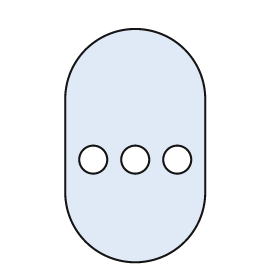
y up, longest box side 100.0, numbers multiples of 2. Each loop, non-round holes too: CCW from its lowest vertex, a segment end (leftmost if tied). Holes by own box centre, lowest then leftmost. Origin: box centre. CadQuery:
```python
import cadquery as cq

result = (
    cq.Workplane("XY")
    .moveTo(-30.0, -20.0)
    .threePointArc((0.0, -50.0), (30.0, -20.0))
    .lineTo(30.0, 20.0)
    .threePointArc((0.0, 50.0), (-30.0, 20.0))
    .close()
    .moveTo(-18.0, -6.0)
    .circle(6.0)
    .moveTo(0.0, -6.0)
    .circle(6.0)
    .moveTo(18.0, -6.0)
    .circle(6.0)
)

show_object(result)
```